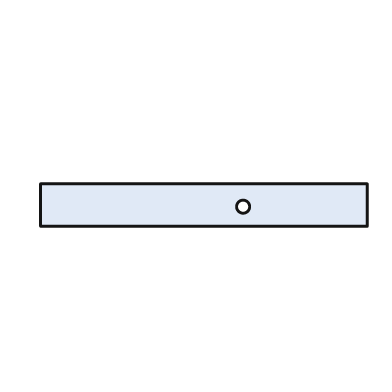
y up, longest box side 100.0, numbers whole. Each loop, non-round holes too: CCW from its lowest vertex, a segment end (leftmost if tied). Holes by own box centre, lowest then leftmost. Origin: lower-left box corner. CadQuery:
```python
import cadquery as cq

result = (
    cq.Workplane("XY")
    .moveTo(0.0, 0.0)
    .lineTo(100.0, 0.0)
    .lineTo(100.0, 13.0)
    .lineTo(0.0, 13.0)
    .close()
    .moveTo(62.0, 6.0)
    .circle(2.0)
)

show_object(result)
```